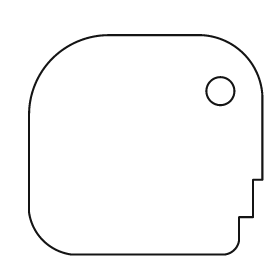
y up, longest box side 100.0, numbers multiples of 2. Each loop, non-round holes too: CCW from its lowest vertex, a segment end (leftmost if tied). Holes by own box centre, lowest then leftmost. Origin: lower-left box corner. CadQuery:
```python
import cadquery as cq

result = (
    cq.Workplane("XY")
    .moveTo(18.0, 0.0)
    .lineTo(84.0, 0.0)
    .threePointArc((88.0, 2.0), (90.0, 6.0))
    .lineTo(90.0, 16.0)
    .lineTo(96.0, 16.0)
    .lineTo(96.0, 32.0)
    .lineTo(100.0, 32.0)
    .lineTo(100.0, 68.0)
    .threePointArc((92.0, 86.0), (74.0, 94.0))
    .lineTo(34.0, 94.0)
    .threePointArc((10.0, 84.0), (0.0, 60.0))
    .lineTo(0.0, 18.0)
    .threePointArc((6.0, 6.0), (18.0, 0.0))
    .close()
    .moveTo(82.0, 70.0)
    .circle(6.0)
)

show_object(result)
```